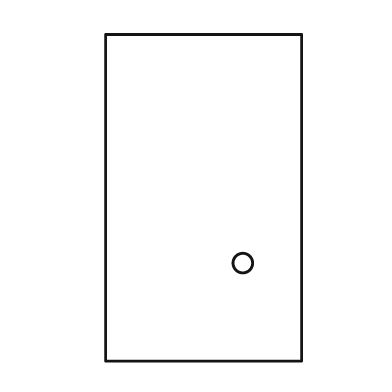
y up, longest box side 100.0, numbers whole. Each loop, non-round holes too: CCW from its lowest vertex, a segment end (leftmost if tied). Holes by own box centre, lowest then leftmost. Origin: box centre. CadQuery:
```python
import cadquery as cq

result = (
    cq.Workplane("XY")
    .moveTo(-30.0, -50.0)
    .lineTo(30.0, -50.0)
    .lineTo(30.0, 50.0)
    .lineTo(-30.0, 50.0)
    .close()
    .moveTo(12.0, -20.0)
    .circle(3.0)
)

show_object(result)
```